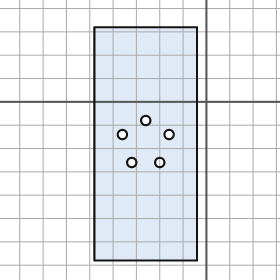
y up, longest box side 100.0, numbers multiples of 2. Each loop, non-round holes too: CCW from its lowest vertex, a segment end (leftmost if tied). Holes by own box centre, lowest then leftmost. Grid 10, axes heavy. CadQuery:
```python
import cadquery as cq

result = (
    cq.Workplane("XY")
    .moveTo(-48.0, -68.0)
    .lineTo(-4.0, -68.0)
    .lineTo(-4.0, 32.0)
    .lineTo(-48.0, 32.0)
    .close()
    .moveTo(-32.0, -26.0)
    .circle(2.0)
    .moveTo(-20.0, -26.0)
    .circle(2.0)
    .moveTo(-36.0, -14.0)
    .circle(2.0)
    .moveTo(-16.0, -14.0)
    .circle(2.0)
    .moveTo(-26.0, -8.0)
    .circle(2.0)
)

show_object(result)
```